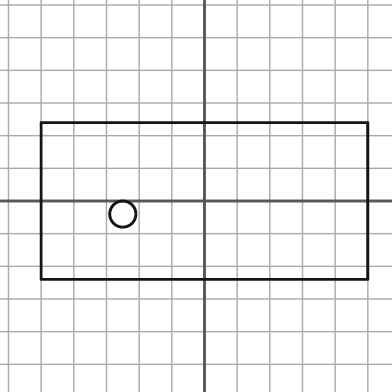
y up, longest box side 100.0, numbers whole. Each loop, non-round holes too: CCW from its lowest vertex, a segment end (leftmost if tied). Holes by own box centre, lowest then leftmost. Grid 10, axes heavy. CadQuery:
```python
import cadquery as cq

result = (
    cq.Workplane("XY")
    .moveTo(-50.0, -24.0)
    .lineTo(50.0, -24.0)
    .lineTo(50.0, 24.0)
    .lineTo(-50.0, 24.0)
    .close()
    .moveTo(-25.0, -4.0)
    .circle(4.0)
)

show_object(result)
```